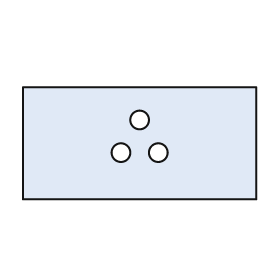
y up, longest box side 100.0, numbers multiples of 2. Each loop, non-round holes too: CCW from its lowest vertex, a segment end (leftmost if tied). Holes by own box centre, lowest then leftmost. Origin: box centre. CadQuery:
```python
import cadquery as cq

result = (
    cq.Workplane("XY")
    .moveTo(-50.0, -24.0)
    .lineTo(50.0, -24.0)
    .lineTo(50.0, 24.0)
    .lineTo(-50.0, 24.0)
    .close()
    .moveTo(-8.0, -4.0)
    .circle(4.0)
    .moveTo(8.0, -4.0)
    .circle(4.0)
    .moveTo(0.0, 10.0)
    .circle(4.0)
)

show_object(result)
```